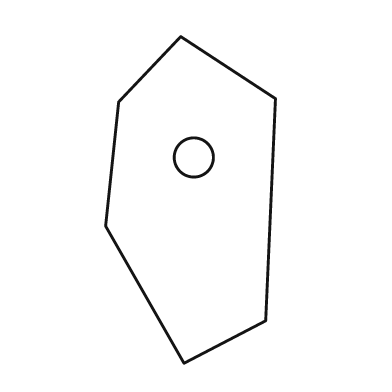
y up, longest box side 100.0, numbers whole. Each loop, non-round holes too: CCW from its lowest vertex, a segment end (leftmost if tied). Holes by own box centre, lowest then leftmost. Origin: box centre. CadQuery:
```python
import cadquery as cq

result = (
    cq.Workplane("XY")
    .moveTo(-2.0, -50.0)
    .lineTo(23.0, -37.0)
    .lineTo(26.0, 31.0)
    .lineTo(-3.0, 50.0)
    .lineTo(-22.0, 30.0)
    .lineTo(-26.0, -8.0)
    .close()
    .moveTo(1.0, 13.0)
    .circle(6.0)
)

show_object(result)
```